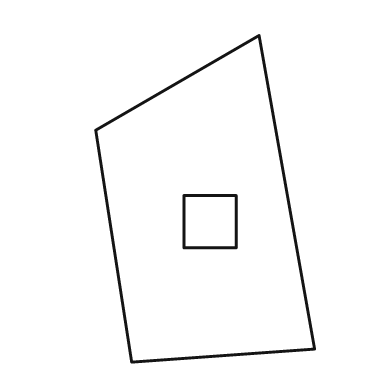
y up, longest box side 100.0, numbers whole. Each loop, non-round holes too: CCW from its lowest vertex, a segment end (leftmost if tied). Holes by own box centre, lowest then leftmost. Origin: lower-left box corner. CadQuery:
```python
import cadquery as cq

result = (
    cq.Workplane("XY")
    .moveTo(11.0, 0.0)
    .lineTo(67.0, 4.0)
    .lineTo(50.0, 100.0)
    .lineTo(0.0, 71.0)
    .close()
    .moveTo(27.0, 35.0)
    .lineTo(43.0, 35.0)
    .lineTo(43.0, 51.0)
    .lineTo(27.0, 51.0)
    .close()
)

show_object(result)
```